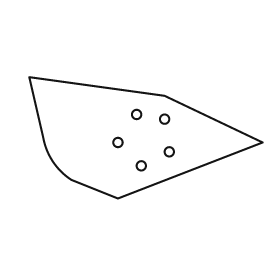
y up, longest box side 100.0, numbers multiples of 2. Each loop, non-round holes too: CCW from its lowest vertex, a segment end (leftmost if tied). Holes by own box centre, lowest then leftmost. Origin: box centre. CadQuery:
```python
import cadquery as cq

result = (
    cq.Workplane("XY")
    .moveTo(-12.0, -26.0)
    .lineTo(50.0, -2.0)
    .lineTo(8.0, 18.0)
    .lineTo(-50.0, 26.0)
    .lineTo(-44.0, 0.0)
    .threePointArc((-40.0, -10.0), (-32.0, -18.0))
    .close()
    .moveTo(-2.0, -12.0)
    .circle(2.0)
    .moveTo(10.0, -6.0)
    .circle(2.0)
    .moveTo(-12.0, -2.0)
    .circle(2.0)
    .moveTo(8.0, 8.0)
    .circle(2.0)
    .moveTo(-4.0, 10.0)
    .circle(2.0)
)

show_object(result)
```